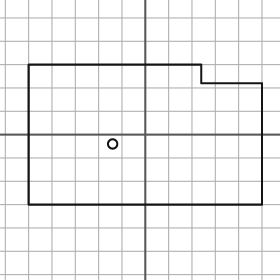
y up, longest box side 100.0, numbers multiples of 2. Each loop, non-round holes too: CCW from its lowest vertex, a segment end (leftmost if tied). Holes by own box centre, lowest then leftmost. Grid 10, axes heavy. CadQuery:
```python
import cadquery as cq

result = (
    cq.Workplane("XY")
    .moveTo(-50.0, -30.0)
    .lineTo(50.0, -30.0)
    .lineTo(50.0, 22.0)
    .lineTo(24.0, 22.0)
    .lineTo(24.0, 30.0)
    .lineTo(-50.0, 30.0)
    .close()
    .moveTo(-14.0, -4.0)
    .circle(2.0)
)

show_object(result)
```